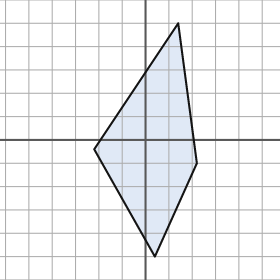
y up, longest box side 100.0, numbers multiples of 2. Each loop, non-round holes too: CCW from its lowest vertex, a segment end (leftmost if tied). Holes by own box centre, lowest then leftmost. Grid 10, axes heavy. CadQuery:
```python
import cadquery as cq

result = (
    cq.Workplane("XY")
    .moveTo(4.0, -50.0)
    .lineTo(22.0, -10.0)
    .lineTo(14.0, 50.0)
    .lineTo(-22.0, -4.0)
    .close()
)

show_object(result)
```